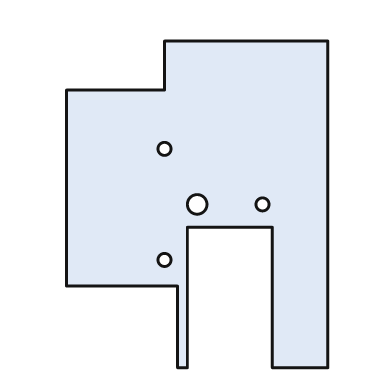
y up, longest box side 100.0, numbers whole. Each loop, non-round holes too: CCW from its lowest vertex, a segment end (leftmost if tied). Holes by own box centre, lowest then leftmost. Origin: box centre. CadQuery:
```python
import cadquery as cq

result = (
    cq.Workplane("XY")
    .moveTo(-6.0, -50.0)
    .lineTo(-3.0, -50.0)
    .lineTo(-3.0, -7.0)
    .lineTo(23.0, -7.0)
    .lineTo(23.0, -50.0)
    .lineTo(40.0, -50.0)
    .lineTo(40.0, 50.0)
    .lineTo(-10.0, 50.0)
    .lineTo(-10.0, 35.0)
    .lineTo(-40.0, 35.0)
    .lineTo(-40.0, -25.0)
    .lineTo(-6.0, -25.0)
    .close()
    .moveTo(-10.0, -17.0)
    .circle(2.0)
    .moveTo(0.0, 0.0)
    .circle(3.0)
    .moveTo(20.0, 0.0)
    .circle(2.0)
    .moveTo(-10.0, 17.0)
    .circle(2.0)
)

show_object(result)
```